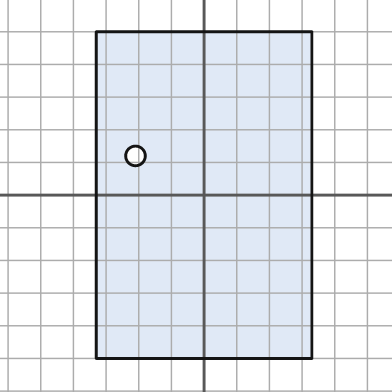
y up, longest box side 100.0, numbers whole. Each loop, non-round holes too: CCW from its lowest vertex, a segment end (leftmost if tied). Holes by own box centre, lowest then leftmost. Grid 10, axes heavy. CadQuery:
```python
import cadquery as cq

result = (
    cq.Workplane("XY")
    .moveTo(-33.0, -50.0)
    .lineTo(33.0, -50.0)
    .lineTo(33.0, 50.0)
    .lineTo(-33.0, 50.0)
    .close()
    .moveTo(-21.0, 12.0)
    .circle(3.0)
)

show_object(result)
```